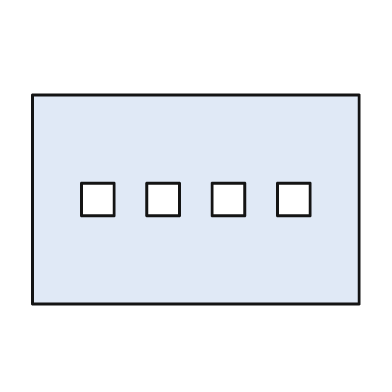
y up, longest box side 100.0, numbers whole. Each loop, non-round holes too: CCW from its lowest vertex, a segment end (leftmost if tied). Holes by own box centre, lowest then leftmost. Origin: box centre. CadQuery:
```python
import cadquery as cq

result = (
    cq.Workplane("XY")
    .moveTo(-50.0, -32.0)
    .lineTo(50.0, -32.0)
    .lineTo(50.0, 32.0)
    .lineTo(-50.0, 32.0)
    .close()
    .moveTo(-35.0, -5.0)
    .lineTo(-25.0, -5.0)
    .lineTo(-25.0, 5.0)
    .lineTo(-35.0, 5.0)
    .close()
    .moveTo(-15.0, -5.0)
    .lineTo(-5.0, -5.0)
    .lineTo(-5.0, 5.0)
    .lineTo(-15.0, 5.0)
    .close()
    .moveTo(5.0, -5.0)
    .lineTo(15.0, -5.0)
    .lineTo(15.0, 5.0)
    .lineTo(5.0, 5.0)
    .close()
    .moveTo(25.0, -5.0)
    .lineTo(35.0, -5.0)
    .lineTo(35.0, 5.0)
    .lineTo(25.0, 5.0)
    .close()
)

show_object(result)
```